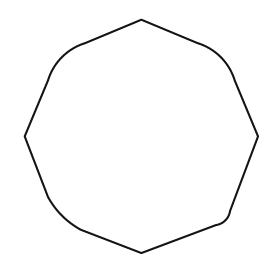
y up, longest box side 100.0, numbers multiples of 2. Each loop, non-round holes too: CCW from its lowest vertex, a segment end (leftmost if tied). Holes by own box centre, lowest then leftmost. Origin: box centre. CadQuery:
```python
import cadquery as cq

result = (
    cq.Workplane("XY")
    .moveTo(0.0, -50.0)
    .lineTo(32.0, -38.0)
    .threePointArc((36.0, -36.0), (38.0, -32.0))
    .lineTo(50.0, 0.0)
    .lineTo(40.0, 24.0)
    .threePointArc((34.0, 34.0), (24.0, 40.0))
    .lineTo(0.0, 50.0)
    .lineTo(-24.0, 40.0)
    .threePointArc((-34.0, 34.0), (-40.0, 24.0))
    .lineTo(-50.0, 0.0)
    .lineTo(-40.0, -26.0)
    .threePointArc((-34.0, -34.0), (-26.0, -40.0))
    .close()
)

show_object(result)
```